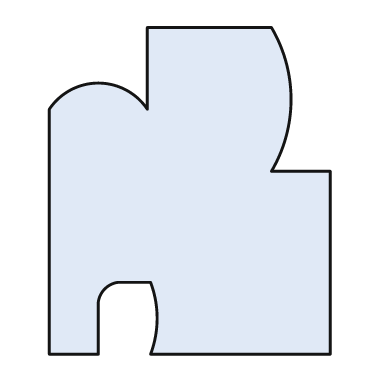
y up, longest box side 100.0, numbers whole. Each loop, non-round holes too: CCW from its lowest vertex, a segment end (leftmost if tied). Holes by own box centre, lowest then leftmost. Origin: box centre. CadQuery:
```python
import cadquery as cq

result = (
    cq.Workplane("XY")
    .moveTo(-43.0, -50.0)
    .lineTo(-28.0, -50.0)
    .lineTo(-28.0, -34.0)
    .threePointArc((-26.0, -30.0), (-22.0, -28.0))
    .lineTo(-12.0, -28.0)
    .threePointArc((-10.0, -39.0), (-12.0, -50.0))
    .lineTo(43.0, -50.0)
    .lineTo(43.0, 6.0)
    .lineTo(25.0, 6.0)
    .threePointArc((31.0, 28.0), (25.0, 50.0))
    .lineTo(-13.0, 50.0)
    .lineTo(-13.0, 25.0)
    .threePointArc((-28.0, 33.0), (-43.0, 25.0))
    .close()
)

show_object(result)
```